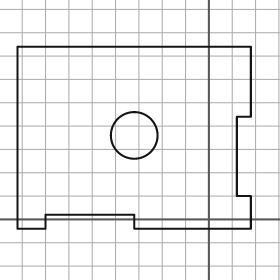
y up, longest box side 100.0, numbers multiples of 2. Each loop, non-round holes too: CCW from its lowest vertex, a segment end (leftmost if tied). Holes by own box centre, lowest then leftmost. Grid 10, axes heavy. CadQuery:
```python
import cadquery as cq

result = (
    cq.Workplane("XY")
    .moveTo(-82.0, -4.0)
    .lineTo(-70.0, -4.0)
    .lineTo(-70.0, 2.0)
    .lineTo(-32.0, 2.0)
    .lineTo(-32.0, -4.0)
    .lineTo(18.0, -4.0)
    .lineTo(18.0, 10.0)
    .lineTo(12.0, 10.0)
    .lineTo(12.0, 44.0)
    .lineTo(18.0, 44.0)
    .lineTo(18.0, 74.0)
    .lineTo(-82.0, 74.0)
    .close()
    .moveTo(-32.0, 36.0)
    .circle(10.0)
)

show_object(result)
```